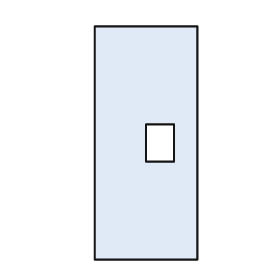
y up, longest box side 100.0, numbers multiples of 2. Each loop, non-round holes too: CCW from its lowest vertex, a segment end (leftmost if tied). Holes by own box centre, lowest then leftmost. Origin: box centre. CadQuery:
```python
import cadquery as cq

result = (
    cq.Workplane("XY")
    .moveTo(-22.0, -50.0)
    .lineTo(22.0, -50.0)
    .lineTo(22.0, 50.0)
    .lineTo(-22.0, 50.0)
    .close()
    .moveTo(0.0, -8.0)
    .lineTo(12.0, -8.0)
    .lineTo(12.0, 8.0)
    .lineTo(0.0, 8.0)
    .close()
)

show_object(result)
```